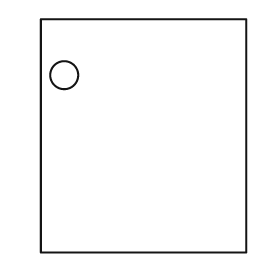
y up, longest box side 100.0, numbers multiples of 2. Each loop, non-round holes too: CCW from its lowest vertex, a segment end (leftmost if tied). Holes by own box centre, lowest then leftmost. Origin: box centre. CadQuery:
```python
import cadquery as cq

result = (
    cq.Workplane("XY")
    .moveTo(-44.0, -50.0)
    .lineTo(44.0, -50.0)
    .lineTo(44.0, 50.0)
    .lineTo(-44.0, 50.0)
    .close()
    .moveTo(-34.0, 26.0)
    .circle(6.0)
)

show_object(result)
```